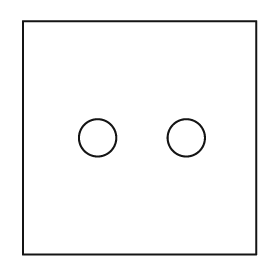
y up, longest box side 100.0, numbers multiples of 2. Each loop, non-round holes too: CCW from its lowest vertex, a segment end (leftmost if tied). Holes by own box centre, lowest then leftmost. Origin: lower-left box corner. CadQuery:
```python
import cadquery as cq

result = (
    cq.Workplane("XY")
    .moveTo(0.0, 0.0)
    .lineTo(100.0, 0.0)
    .lineTo(100.0, 100.0)
    .lineTo(0.0, 100.0)
    .close()
    .moveTo(32.0, 50.0)
    .circle(8.0)
    .moveTo(70.0, 50.0)
    .circle(8.0)
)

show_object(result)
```